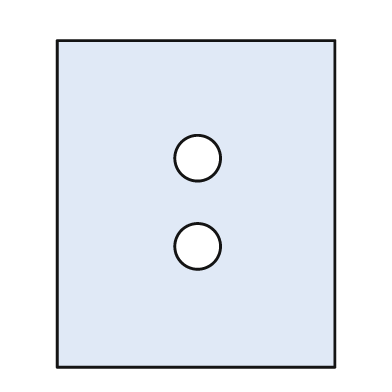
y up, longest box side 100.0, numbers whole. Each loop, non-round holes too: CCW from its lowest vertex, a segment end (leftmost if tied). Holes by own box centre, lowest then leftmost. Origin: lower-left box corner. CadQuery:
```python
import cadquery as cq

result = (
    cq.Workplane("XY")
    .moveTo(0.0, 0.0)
    .lineTo(85.0, 0.0)
    .lineTo(85.0, 100.0)
    .lineTo(0.0, 100.0)
    .close()
    .moveTo(43.0, 37.0)
    .circle(7.0)
    .moveTo(43.0, 64.0)
    .circle(7.0)
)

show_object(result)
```